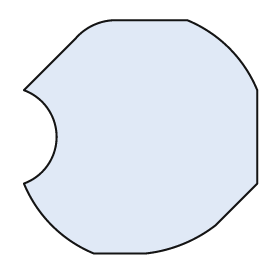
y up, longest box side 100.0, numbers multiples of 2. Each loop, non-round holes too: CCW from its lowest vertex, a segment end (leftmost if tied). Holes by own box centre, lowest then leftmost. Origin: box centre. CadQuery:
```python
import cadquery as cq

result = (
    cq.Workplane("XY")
    .moveTo(-20.0, -50.0)
    .lineTo(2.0, -50.0)
    .threePointArc((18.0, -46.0), (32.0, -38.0))
    .lineTo(50.0, -20.0)
    .lineTo(50.0, 20.0)
    .threePointArc((38.0, 38.0), (20.0, 50.0))
    .lineTo(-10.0, 50.0)
    .threePointArc((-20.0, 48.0), (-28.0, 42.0))
    .lineTo(-50.0, 20.0)
    .threePointArc((-36.0, 0.0), (-50.0, -20.0))
    .threePointArc((-38.0, -38.0), (-20.0, -50.0))
    .close()
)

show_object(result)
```